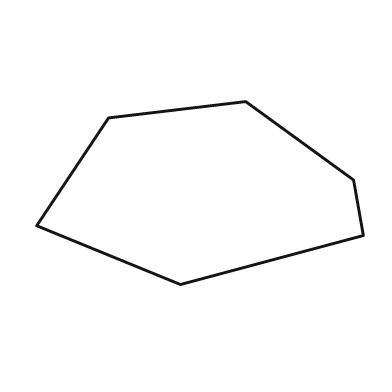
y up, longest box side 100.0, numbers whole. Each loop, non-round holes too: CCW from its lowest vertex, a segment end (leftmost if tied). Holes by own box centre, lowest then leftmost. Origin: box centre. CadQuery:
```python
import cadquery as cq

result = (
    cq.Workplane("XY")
    .moveTo(-6.0, -28.0)
    .lineTo(50.0, -13.0)
    .lineTo(47.0, 4.0)
    .lineTo(14.0, 28.0)
    .lineTo(-28.0, 23.0)
    .lineTo(-50.0, -10.0)
    .close()
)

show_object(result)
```